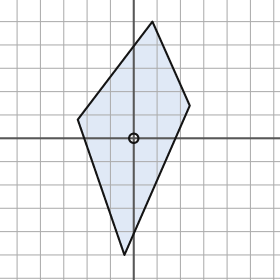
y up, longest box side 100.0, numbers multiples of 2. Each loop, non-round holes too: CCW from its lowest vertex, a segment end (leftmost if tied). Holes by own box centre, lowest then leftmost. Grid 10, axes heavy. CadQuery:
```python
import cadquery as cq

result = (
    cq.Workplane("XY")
    .moveTo(-4.0, -50.0)
    .lineTo(24.0, 14.0)
    .lineTo(8.0, 50.0)
    .lineTo(-24.0, 8.0)
    .close()
    .moveTo(0.0, 0.0)
    .circle(2.0)
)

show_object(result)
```